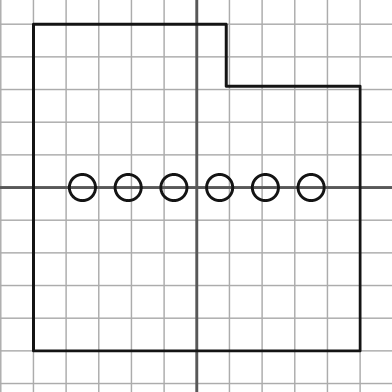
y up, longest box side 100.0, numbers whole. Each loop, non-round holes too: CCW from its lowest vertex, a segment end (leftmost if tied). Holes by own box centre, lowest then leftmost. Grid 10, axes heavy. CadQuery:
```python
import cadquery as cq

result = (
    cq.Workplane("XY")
    .moveTo(-50.0, -50.0)
    .lineTo(50.0, -50.0)
    .lineTo(50.0, 31.0)
    .lineTo(9.0, 31.0)
    .lineTo(9.0, 50.0)
    .lineTo(-50.0, 50.0)
    .close()
    .moveTo(-35.0, 0.0)
    .circle(4.0)
    .moveTo(-21.0, 0.0)
    .circle(4.0)
    .moveTo(-7.0, 0.0)
    .circle(4.0)
    .moveTo(7.0, 0.0)
    .circle(4.0)
    .moveTo(21.0, 0.0)
    .circle(4.0)
    .moveTo(35.0, 0.0)
    .circle(4.0)
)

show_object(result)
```